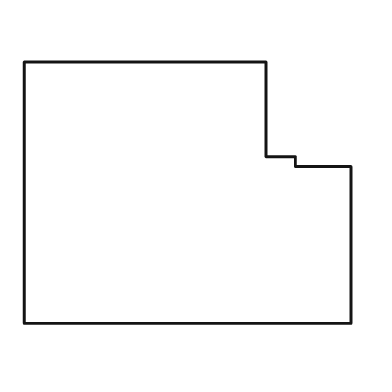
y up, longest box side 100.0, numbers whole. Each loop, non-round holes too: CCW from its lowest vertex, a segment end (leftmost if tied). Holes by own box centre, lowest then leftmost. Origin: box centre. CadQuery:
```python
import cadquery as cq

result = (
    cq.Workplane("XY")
    .moveTo(-50.0, -40.0)
    .lineTo(50.0, -40.0)
    .lineTo(50.0, 8.0)
    .lineTo(33.0, 8.0)
    .lineTo(33.0, 11.0)
    .lineTo(24.0, 11.0)
    .lineTo(24.0, 40.0)
    .lineTo(-50.0, 40.0)
    .close()
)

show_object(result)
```